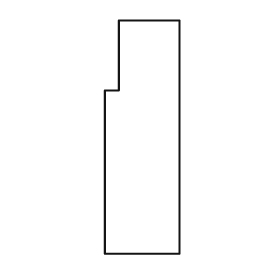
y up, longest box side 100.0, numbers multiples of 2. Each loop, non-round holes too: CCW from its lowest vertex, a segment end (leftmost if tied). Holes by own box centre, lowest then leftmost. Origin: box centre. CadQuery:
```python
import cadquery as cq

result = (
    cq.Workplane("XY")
    .moveTo(-16.0, -50.0)
    .lineTo(16.0, -50.0)
    .lineTo(16.0, 50.0)
    .lineTo(-10.0, 50.0)
    .lineTo(-10.0, 20.0)
    .lineTo(-16.0, 20.0)
    .close()
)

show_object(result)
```